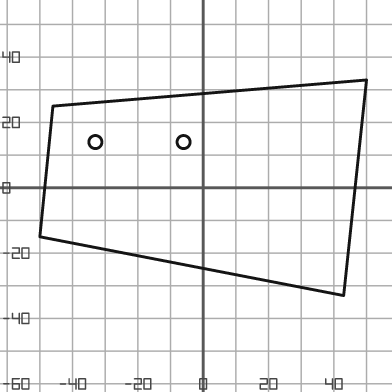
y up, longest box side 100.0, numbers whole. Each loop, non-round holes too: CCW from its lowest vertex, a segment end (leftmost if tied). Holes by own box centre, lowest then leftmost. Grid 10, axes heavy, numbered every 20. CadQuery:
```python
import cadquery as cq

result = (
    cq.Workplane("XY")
    .moveTo(43.0, -33.0)
    .lineTo(50.0, 33.0)
    .lineTo(-46.0, 25.0)
    .lineTo(-50.0, -15.0)
    .close()
    .moveTo(-33.0, 14.0)
    .circle(2.0)
    .moveTo(-6.0, 14.0)
    .circle(2.0)
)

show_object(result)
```